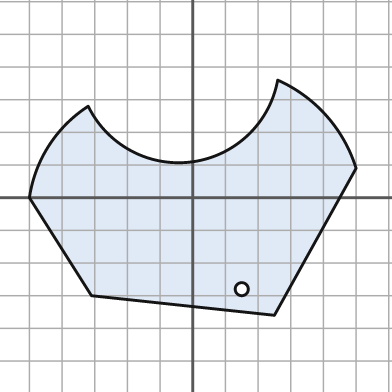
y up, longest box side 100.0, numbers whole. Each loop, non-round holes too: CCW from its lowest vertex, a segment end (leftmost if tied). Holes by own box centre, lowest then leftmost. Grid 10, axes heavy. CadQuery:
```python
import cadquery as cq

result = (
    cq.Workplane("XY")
    .moveTo(25.0, -36.0)
    .lineTo(50.0, 9.0)
    .threePointArc((41.0, 25.0), (26.0, 36.0))
    .threePointArc((0.0, 11.0), (-32.0, 28.0))
    .threePointArc((-44.0, 16.0), (-50.0, 0.0))
    .lineTo(-31.0, -30.0)
    .close()
    .moveTo(15.0, -28.0)
    .circle(2.0)
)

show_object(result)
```